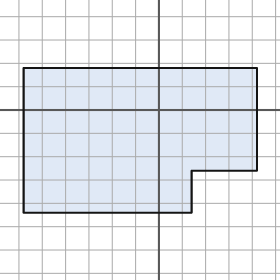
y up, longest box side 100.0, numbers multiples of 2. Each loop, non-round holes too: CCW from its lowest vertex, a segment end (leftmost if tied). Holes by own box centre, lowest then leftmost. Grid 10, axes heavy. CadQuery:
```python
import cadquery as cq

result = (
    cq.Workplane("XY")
    .moveTo(-58.0, -44.0)
    .lineTo(14.0, -44.0)
    .lineTo(14.0, -26.0)
    .lineTo(42.0, -26.0)
    .lineTo(42.0, 18.0)
    .lineTo(-58.0, 18.0)
    .close()
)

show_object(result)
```